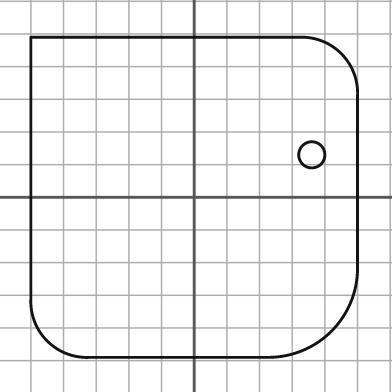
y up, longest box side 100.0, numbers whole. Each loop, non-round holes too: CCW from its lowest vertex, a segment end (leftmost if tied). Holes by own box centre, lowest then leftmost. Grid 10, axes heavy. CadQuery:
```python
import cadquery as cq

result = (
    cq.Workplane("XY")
    .moveTo(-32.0, -49.0)
    .lineTo(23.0, -49.0)
    .threePointArc((42.0, -41.0), (50.0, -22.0))
    .lineTo(50.0, 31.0)
    .threePointArc((45.0, 44.0), (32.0, 49.0))
    .lineTo(-50.0, 49.0)
    .lineTo(-50.0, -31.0)
    .threePointArc((-45.0, -44.0), (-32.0, -49.0))
    .close()
    .moveTo(36.0, 13.0)
    .circle(4.0)
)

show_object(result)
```